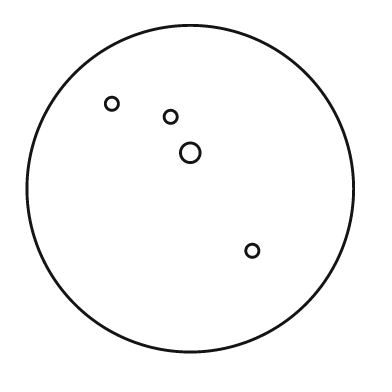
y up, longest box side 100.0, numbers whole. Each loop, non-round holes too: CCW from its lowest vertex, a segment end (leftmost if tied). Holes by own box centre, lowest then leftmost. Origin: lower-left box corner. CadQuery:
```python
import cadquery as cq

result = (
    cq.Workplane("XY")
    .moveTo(50.0, 50.0)
    .circle(50.0)
    .moveTo(69.0, 31.0)
    .circle(2.0)
    .moveTo(50.0, 61.0)
    .circle(3.0)
    .moveTo(44.0, 72.0)
    .circle(2.0)
    .moveTo(26.0, 76.0)
    .circle(2.0)
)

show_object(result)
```